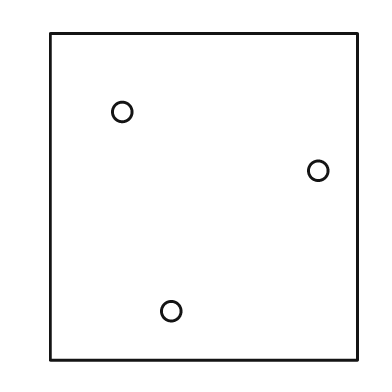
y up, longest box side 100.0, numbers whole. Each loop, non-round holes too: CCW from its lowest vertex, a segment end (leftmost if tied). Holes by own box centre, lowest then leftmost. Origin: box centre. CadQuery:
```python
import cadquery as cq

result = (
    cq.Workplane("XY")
    .moveTo(-47.0, -50.0)
    .lineTo(47.0, -50.0)
    .lineTo(47.0, 50.0)
    .lineTo(-47.0, 50.0)
    .close()
    .moveTo(-10.0, -35.0)
    .circle(3.0)
    .moveTo(35.0, 8.0)
    .circle(3.0)
    .moveTo(-25.0, 26.0)
    .circle(3.0)
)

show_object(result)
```